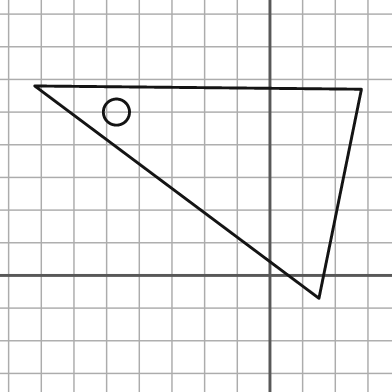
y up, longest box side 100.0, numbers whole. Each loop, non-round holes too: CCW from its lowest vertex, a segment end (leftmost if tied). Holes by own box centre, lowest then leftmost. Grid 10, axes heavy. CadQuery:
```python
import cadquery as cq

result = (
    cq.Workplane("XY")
    .moveTo(15.0, -7.0)
    .lineTo(28.0, 57.0)
    .lineTo(-72.0, 58.0)
    .close()
    .moveTo(-47.0, 50.0)
    .circle(4.0)
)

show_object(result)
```